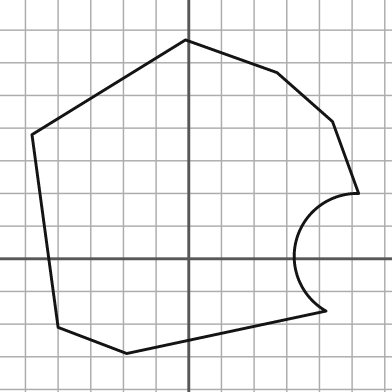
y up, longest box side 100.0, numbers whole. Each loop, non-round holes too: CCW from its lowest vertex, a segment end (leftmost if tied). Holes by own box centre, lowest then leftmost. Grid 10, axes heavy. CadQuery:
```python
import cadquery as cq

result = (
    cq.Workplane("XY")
    .moveTo(-19.0, -29.0)
    .lineTo(42.0, -16.0)
    .threePointArc((33.0, 6.0), (52.0, 20.0))
    .lineTo(44.0, 42.0)
    .lineTo(27.0, 57.0)
    .lineTo(-1.0, 67.0)
    .lineTo(-48.0, 38.0)
    .lineTo(-40.0, -21.0)
    .close()
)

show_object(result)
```